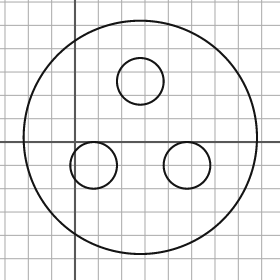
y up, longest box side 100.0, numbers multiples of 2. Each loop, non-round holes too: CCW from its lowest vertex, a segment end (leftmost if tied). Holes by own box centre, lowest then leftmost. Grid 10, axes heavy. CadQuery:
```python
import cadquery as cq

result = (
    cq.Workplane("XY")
    .moveTo(28.0, 2.0)
    .circle(50.0)
    .moveTo(8.0, -10.0)
    .circle(10.0)
    .moveTo(48.0, -10.0)
    .circle(10.0)
    .moveTo(28.0, 26.0)
    .circle(10.0)
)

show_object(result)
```